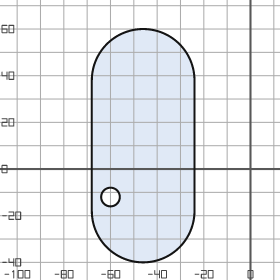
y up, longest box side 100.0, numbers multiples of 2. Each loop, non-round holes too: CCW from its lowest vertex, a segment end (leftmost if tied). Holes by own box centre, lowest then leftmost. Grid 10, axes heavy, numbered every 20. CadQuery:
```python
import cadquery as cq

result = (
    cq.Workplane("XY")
    .moveTo(-68.0, -18.0)
    .threePointArc((-46.0, -40.0), (-24.0, -18.0))
    .lineTo(-24.0, 38.0)
    .threePointArc((-46.0, 60.0), (-68.0, 38.0))
    .close()
    .moveTo(-60.0, -12.0)
    .circle(4.0)
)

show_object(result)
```